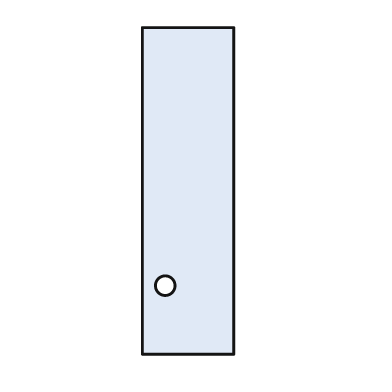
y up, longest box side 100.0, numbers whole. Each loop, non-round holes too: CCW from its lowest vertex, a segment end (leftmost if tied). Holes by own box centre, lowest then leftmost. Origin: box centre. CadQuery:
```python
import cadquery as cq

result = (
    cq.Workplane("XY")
    .moveTo(-14.0, -50.0)
    .lineTo(14.0, -50.0)
    .lineTo(14.0, 50.0)
    .lineTo(-14.0, 50.0)
    .close()
    .moveTo(-7.0, -29.0)
    .circle(3.0)
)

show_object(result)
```